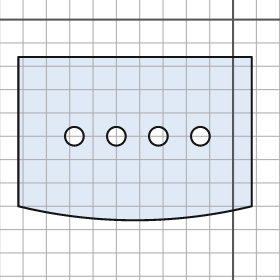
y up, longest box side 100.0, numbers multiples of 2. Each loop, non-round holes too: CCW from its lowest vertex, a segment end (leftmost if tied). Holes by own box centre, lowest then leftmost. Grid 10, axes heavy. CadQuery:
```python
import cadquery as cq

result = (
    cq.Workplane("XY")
    .moveTo(-92.0, -80.0)
    .threePointArc((-42.0, -86.0), (8.0, -80.0))
    .lineTo(8.0, -16.0)
    .lineTo(-92.0, -16.0)
    .close()
    .moveTo(-68.0, -50.0)
    .circle(4.0)
    .moveTo(-50.0, -50.0)
    .circle(4.0)
    .moveTo(-32.0, -50.0)
    .circle(4.0)
    .moveTo(-14.0, -50.0)
    .circle(4.0)
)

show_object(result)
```